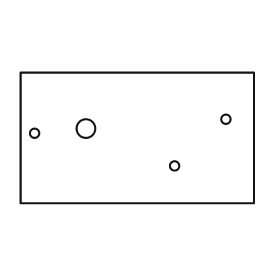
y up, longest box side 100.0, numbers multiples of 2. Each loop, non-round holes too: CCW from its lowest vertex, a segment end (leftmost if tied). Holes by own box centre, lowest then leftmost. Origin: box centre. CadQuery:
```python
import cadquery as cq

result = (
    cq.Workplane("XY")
    .moveTo(-50.0, -28.0)
    .lineTo(50.0, -28.0)
    .lineTo(50.0, 28.0)
    .lineTo(-50.0, 28.0)
    .close()
    .moveTo(16.0, -12.0)
    .circle(2.0)
    .moveTo(-44.0, 2.0)
    .circle(2.0)
    .moveTo(-22.0, 4.0)
    .circle(4.0)
    .moveTo(38.0, 8.0)
    .circle(2.0)
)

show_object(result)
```